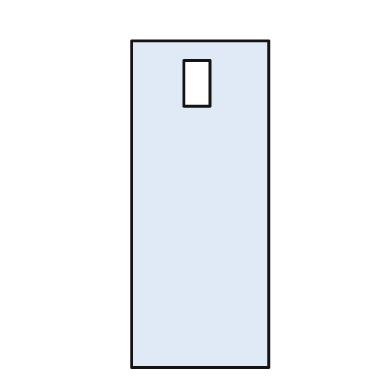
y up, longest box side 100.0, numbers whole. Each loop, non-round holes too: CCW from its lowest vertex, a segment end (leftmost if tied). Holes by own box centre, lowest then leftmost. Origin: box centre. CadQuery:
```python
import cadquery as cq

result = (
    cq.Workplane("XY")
    .moveTo(-21.0, -50.0)
    .lineTo(21.0, -50.0)
    .lineTo(21.0, 50.0)
    .lineTo(-21.0, 50.0)
    .close()
    .moveTo(-5.0, 30.0)
    .lineTo(3.0, 30.0)
    .lineTo(3.0, 44.0)
    .lineTo(-5.0, 44.0)
    .close()
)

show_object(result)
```